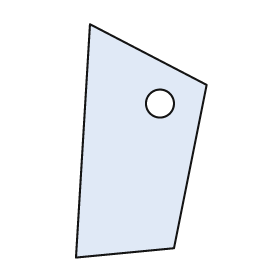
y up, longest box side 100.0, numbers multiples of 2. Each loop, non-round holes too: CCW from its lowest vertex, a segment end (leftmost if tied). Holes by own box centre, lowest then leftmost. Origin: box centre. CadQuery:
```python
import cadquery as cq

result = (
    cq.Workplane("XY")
    .moveTo(-28.0, -50.0)
    .lineTo(14.0, -46.0)
    .lineTo(28.0, 24.0)
    .lineTo(-22.0, 50.0)
    .close()
    .moveTo(8.0, 16.0)
    .circle(6.0)
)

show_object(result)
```